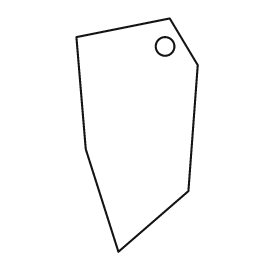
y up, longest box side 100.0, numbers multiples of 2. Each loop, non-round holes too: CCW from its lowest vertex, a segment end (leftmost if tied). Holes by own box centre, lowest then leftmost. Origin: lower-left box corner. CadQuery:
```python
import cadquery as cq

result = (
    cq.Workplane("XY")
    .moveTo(18.0, 0.0)
    .lineTo(48.0, 26.0)
    .lineTo(52.0, 80.0)
    .lineTo(40.0, 100.0)
    .lineTo(0.0, 92.0)
    .lineTo(4.0, 44.0)
    .close()
    .moveTo(38.0, 88.0)
    .circle(4.0)
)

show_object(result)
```